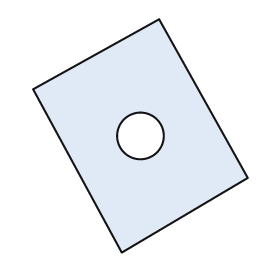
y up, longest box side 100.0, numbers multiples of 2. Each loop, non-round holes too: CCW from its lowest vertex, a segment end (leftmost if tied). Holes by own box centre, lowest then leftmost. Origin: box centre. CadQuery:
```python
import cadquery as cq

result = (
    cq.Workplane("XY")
    .moveTo(-8.0, -50.0)
    .lineTo(46.0, -18.0)
    .lineTo(8.0, 50.0)
    .lineTo(-46.0, 20.0)
    .close()
    .moveTo(0.0, 0.0)
    .circle(10.0)
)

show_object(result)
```